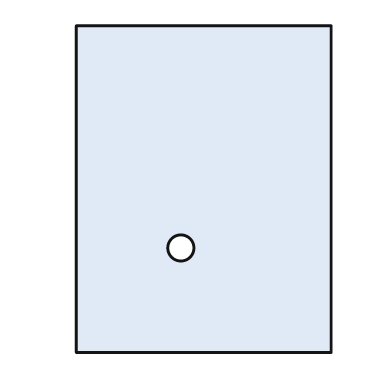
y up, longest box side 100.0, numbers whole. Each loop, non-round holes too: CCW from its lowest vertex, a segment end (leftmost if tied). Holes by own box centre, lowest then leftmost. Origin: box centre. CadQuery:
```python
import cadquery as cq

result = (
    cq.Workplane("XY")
    .moveTo(-39.0, -50.0)
    .lineTo(39.0, -50.0)
    .lineTo(39.0, 50.0)
    .lineTo(-39.0, 50.0)
    .close()
    .moveTo(-7.0, -18.0)
    .circle(4.0)
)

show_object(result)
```